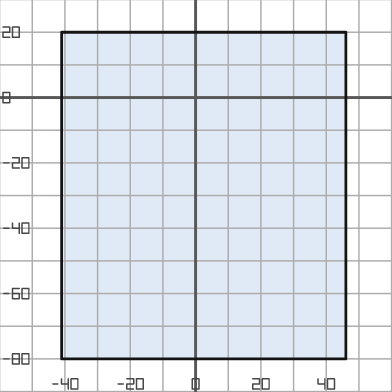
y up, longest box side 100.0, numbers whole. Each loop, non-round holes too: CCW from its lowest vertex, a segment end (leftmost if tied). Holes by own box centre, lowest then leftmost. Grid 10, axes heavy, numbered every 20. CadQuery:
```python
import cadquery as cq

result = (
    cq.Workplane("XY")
    .moveTo(-41.0, -80.0)
    .lineTo(46.0, -80.0)
    .lineTo(46.0, 20.0)
    .lineTo(-41.0, 20.0)
    .close()
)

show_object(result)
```